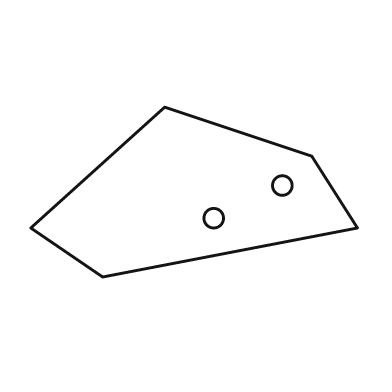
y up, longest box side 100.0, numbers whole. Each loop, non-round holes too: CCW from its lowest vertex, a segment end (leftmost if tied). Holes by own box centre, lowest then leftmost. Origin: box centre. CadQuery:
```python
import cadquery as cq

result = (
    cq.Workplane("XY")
    .moveTo(-28.0, -26.0)
    .lineTo(50.0, -11.0)
    .lineTo(36.0, 11.0)
    .lineTo(-9.0, 26.0)
    .lineTo(-50.0, -11.0)
    .close()
    .moveTo(6.0, -8.0)
    .circle(3.0)
    .moveTo(27.0, 2.0)
    .circle(3.0)
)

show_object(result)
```